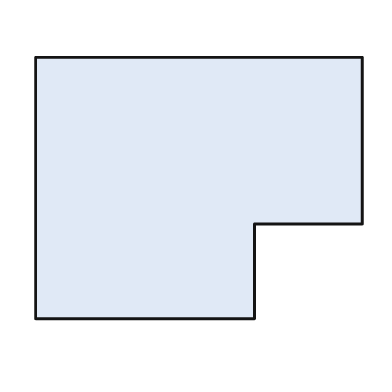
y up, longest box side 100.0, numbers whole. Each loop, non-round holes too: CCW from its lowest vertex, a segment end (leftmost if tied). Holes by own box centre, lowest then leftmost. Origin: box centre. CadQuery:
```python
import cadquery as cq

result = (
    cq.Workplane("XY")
    .moveTo(-50.0, -40.0)
    .lineTo(17.0, -40.0)
    .lineTo(17.0, -11.0)
    .lineTo(50.0, -11.0)
    .lineTo(50.0, 40.0)
    .lineTo(-50.0, 40.0)
    .close()
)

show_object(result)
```